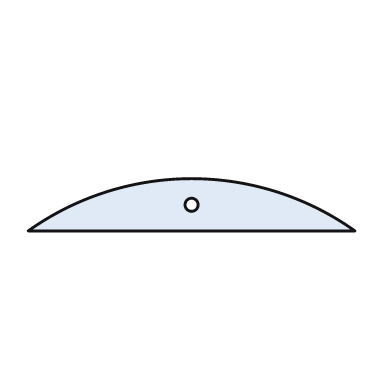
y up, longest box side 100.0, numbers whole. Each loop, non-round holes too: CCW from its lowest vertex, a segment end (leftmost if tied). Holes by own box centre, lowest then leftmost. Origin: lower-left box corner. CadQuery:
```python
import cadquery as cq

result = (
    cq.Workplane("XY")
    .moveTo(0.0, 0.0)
    .lineTo(100.0, 0.0)
    .threePointArc((50.0, 16.0), (0.0, 0.0))
    .close()
    .moveTo(50.0, 8.0)
    .circle(2.0)
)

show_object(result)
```